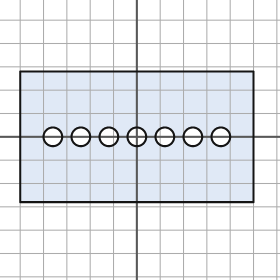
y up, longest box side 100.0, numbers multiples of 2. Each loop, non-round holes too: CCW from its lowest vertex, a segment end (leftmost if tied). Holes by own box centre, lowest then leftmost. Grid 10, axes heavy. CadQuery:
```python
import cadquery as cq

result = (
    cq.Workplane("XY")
    .moveTo(-50.0, -28.0)
    .lineTo(50.0, -28.0)
    .lineTo(50.0, 28.0)
    .lineTo(-50.0, 28.0)
    .close()
    .moveTo(-36.0, 0.0)
    .circle(4.0)
    .moveTo(-24.0, 0.0)
    .circle(4.0)
    .moveTo(-12.0, 0.0)
    .circle(4.0)
    .moveTo(0.0, 0.0)
    .circle(4.0)
    .moveTo(12.0, 0.0)
    .circle(4.0)
    .moveTo(24.0, 0.0)
    .circle(4.0)
    .moveTo(36.0, 0.0)
    .circle(4.0)
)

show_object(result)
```